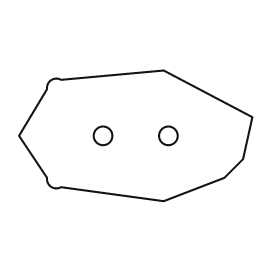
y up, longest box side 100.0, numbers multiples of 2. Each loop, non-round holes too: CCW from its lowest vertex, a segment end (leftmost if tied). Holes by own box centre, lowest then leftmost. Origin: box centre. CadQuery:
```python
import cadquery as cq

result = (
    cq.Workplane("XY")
    .moveTo(12.0, -28.0)
    .lineTo(38.0, -18.0)
    .lineTo(46.0, -10.0)
    .lineTo(50.0, 8.0)
    .lineTo(12.0, 28.0)
    .lineTo(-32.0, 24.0)
    .threePointArc((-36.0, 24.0), (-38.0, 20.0))
    .lineTo(-50.0, 0.0)
    .lineTo(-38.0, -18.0)
    .threePointArc((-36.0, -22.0), (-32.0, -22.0))
    .close()
    .moveTo(-14.0, 0.0)
    .circle(4.0)
    .moveTo(14.0, 0.0)
    .circle(4.0)
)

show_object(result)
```